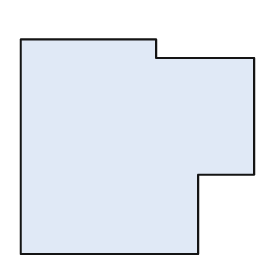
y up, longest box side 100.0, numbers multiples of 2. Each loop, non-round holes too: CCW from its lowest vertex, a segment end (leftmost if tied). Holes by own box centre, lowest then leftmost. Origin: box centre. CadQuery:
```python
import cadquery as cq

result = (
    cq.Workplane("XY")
    .moveTo(-50.0, -46.0)
    .lineTo(26.0, -46.0)
    .lineTo(26.0, -12.0)
    .lineTo(50.0, -12.0)
    .lineTo(50.0, 38.0)
    .lineTo(8.0, 38.0)
    .lineTo(8.0, 46.0)
    .lineTo(-50.0, 46.0)
    .close()
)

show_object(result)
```